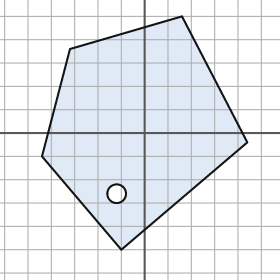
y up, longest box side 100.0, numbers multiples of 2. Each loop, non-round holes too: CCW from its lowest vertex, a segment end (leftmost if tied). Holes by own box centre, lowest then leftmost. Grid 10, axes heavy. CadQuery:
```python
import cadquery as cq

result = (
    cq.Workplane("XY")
    .moveTo(-10.0, -50.0)
    .lineTo(44.0, -4.0)
    .lineTo(16.0, 50.0)
    .lineTo(-32.0, 36.0)
    .lineTo(-44.0, -10.0)
    .close()
    .moveTo(-12.0, -26.0)
    .circle(4.0)
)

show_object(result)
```